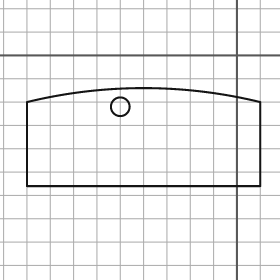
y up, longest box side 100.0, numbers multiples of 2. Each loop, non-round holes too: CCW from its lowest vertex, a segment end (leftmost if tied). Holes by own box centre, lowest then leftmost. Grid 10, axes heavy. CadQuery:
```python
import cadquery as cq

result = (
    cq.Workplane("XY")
    .moveTo(-90.0, -56.0)
    .lineTo(10.0, -56.0)
    .lineTo(10.0, -20.0)
    .threePointArc((-40.0, -14.0), (-90.0, -20.0))
    .close()
    .moveTo(-50.0, -22.0)
    .circle(4.0)
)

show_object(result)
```